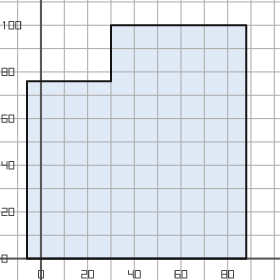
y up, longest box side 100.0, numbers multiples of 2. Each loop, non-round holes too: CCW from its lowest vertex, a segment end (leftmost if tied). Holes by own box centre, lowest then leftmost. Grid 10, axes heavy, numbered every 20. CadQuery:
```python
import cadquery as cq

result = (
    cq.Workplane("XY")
    .moveTo(-6.0, 0.0)
    .lineTo(88.0, 0.0)
    .lineTo(88.0, 100.0)
    .lineTo(30.0, 100.0)
    .lineTo(30.0, 76.0)
    .lineTo(-6.0, 76.0)
    .close()
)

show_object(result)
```